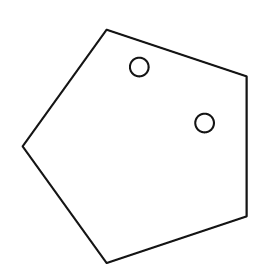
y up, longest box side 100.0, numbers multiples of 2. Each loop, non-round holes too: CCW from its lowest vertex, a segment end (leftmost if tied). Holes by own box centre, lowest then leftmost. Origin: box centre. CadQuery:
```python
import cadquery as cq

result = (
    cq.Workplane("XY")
    .moveTo(-12.0, -50.0)
    .lineTo(48.0, -30.0)
    .lineTo(48.0, 30.0)
    .lineTo(-12.0, 50.0)
    .lineTo(-48.0, 0.0)
    .close()
    .moveTo(30.0, 10.0)
    .circle(4.0)
    .moveTo(2.0, 34.0)
    .circle(4.0)
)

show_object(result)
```